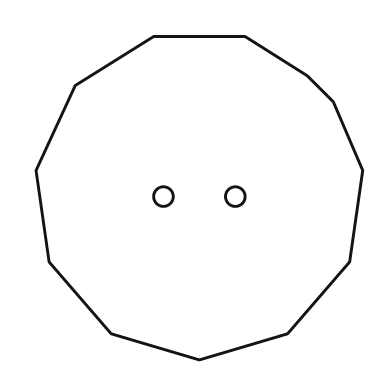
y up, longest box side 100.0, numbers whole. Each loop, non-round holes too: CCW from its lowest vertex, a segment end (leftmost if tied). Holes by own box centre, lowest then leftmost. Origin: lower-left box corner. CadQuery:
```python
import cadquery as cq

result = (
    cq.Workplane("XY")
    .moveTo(50.0, 0.0)
    .lineTo(77.0, 8.0)
    .lineTo(96.0, 30.0)
    .lineTo(100.0, 58.0)
    .lineTo(91.0, 79.0)
    .lineTo(83.0, 87.0)
    .lineTo(64.0, 99.0)
    .lineTo(36.0, 99.0)
    .lineTo(12.0, 84.0)
    .lineTo(0.0, 58.0)
    .lineTo(4.0, 30.0)
    .lineTo(23.0, 8.0)
    .close()
    .moveTo(39.0, 50.0)
    .circle(3.0)
    .moveTo(61.0, 50.0)
    .circle(3.0)
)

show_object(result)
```